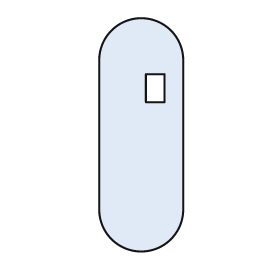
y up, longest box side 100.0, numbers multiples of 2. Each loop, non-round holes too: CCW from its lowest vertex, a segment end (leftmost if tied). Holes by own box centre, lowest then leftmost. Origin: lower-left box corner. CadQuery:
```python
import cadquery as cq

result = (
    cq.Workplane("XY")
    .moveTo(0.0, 18.0)
    .threePointArc((18.0, 0.0), (36.0, 18.0))
    .lineTo(36.0, 82.0)
    .threePointArc((18.0, 100.0), (0.0, 82.0))
    .close()
    .moveTo(20.0, 64.0)
    .lineTo(28.0, 64.0)
    .lineTo(28.0, 76.0)
    .lineTo(20.0, 76.0)
    .close()
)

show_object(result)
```